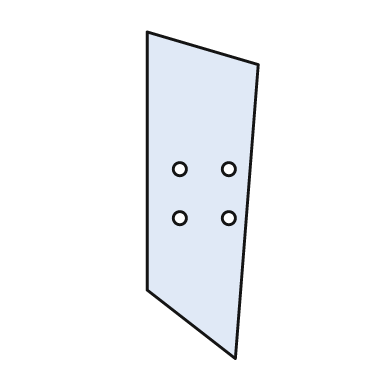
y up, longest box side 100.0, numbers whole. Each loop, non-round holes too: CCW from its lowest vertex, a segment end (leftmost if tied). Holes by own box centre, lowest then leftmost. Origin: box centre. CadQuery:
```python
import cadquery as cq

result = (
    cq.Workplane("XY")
    .moveTo(10.0, -50.0)
    .lineTo(17.0, 40.0)
    .lineTo(-17.0, 50.0)
    .lineTo(-17.0, -29.0)
    .close()
    .moveTo(-7.0, -7.0)
    .circle(2.0)
    .moveTo(8.0, -7.0)
    .circle(2.0)
    .moveTo(-7.0, 8.0)
    .circle(2.0)
    .moveTo(8.0, 8.0)
    .circle(2.0)
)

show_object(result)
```